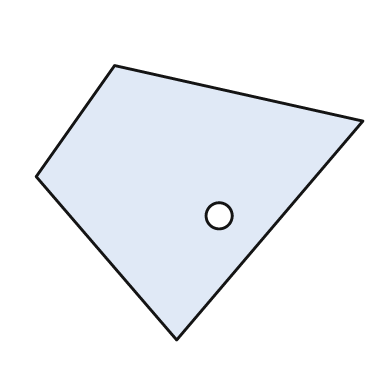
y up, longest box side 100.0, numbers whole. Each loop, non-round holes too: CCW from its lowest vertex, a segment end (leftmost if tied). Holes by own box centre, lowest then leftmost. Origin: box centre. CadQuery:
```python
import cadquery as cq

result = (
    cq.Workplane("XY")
    .moveTo(-7.0, -42.0)
    .lineTo(50.0, 25.0)
    .lineTo(-26.0, 42.0)
    .lineTo(-50.0, 8.0)
    .close()
    .moveTo(6.0, -4.0)
    .circle(4.0)
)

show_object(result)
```